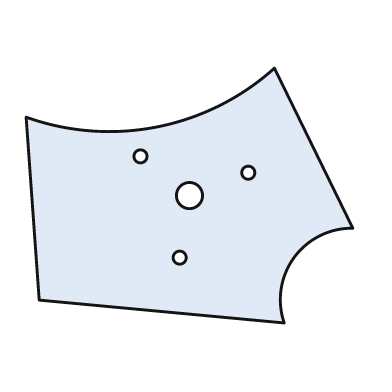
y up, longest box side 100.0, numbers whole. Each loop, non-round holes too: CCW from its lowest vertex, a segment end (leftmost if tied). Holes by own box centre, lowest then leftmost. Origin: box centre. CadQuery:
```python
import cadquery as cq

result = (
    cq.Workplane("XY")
    .moveTo(29.0, -39.0)
    .threePointArc((32.0, -19.0), (50.0, -10.0))
    .lineTo(26.0, 39.0)
    .threePointArc((-10.0, 21.0), (-50.0, 24.0))
    .lineTo(-46.0, -32.0)
    .close()
    .moveTo(-3.0, -19.0)
    .circle(2.0)
    .moveTo(0.0, 0.0)
    .circle(4.0)
    .moveTo(18.0, 7.0)
    .circle(2.0)
    .moveTo(-15.0, 12.0)
    .circle(2.0)
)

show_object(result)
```